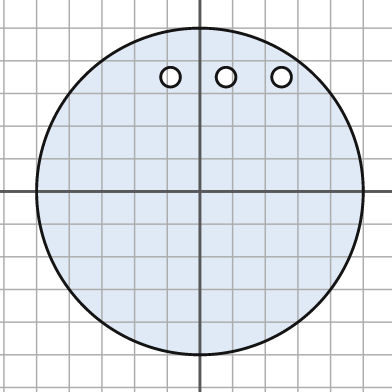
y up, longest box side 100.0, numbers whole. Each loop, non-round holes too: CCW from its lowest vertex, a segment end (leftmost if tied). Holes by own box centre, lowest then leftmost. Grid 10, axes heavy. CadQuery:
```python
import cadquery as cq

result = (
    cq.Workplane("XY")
    .moveTo(0.0, 0.0)
    .circle(50.0)
    .moveTo(-9.0, 35.0)
    .circle(3.0)
    .moveTo(8.0, 35.0)
    .circle(3.0)
    .moveTo(25.0, 35.0)
    .circle(3.0)
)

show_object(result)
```